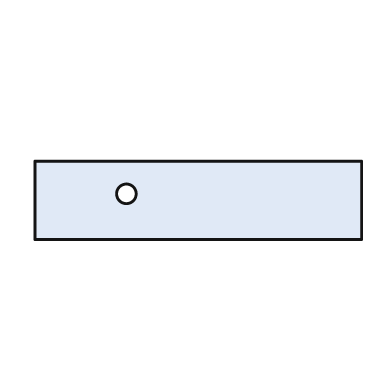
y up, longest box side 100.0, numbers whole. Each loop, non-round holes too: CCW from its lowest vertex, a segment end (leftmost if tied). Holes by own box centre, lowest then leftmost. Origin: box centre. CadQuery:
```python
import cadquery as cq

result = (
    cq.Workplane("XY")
    .moveTo(-50.0, -12.0)
    .lineTo(50.0, -12.0)
    .lineTo(50.0, 12.0)
    .lineTo(-50.0, 12.0)
    .close()
    .moveTo(-22.0, 2.0)
    .circle(3.0)
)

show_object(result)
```